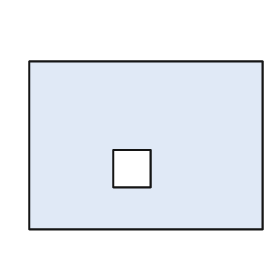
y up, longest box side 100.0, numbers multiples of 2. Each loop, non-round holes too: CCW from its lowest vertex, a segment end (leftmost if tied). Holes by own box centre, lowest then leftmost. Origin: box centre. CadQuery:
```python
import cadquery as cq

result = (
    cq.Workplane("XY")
    .moveTo(-50.0, -36.0)
    .lineTo(50.0, -36.0)
    .lineTo(50.0, 36.0)
    .lineTo(-50.0, 36.0)
    .close()
    .moveTo(-14.0, -18.0)
    .lineTo(2.0, -18.0)
    .lineTo(2.0, -2.0)
    .lineTo(-14.0, -2.0)
    .close()
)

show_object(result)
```